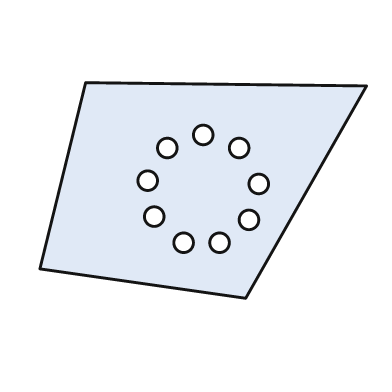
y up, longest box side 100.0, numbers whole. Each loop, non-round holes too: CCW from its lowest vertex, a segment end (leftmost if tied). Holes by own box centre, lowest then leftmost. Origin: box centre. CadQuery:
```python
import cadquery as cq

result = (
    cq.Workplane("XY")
    .moveTo(13.0, -33.0)
    .lineTo(50.0, 32.0)
    .lineTo(-36.0, 33.0)
    .lineTo(-50.0, -24.0)
    .close()
    .moveTo(-6.0, -16.0)
    .circle(3.0)
    .moveTo(5.0, -16.0)
    .circle(3.0)
    .moveTo(14.0, -9.0)
    .circle(3.0)
    .moveTo(-15.0, -8.0)
    .circle(3.0)
    .moveTo(17.0, 2.0)
    .circle(3.0)
    .moveTo(-17.0, 3.0)
    .circle(3.0)
    .moveTo(-11.0, 13.0)
    .circle(3.0)
    .moveTo(11.0, 13.0)
    .circle(3.0)
    .moveTo(0.0, 17.0)
    .circle(3.0)
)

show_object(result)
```